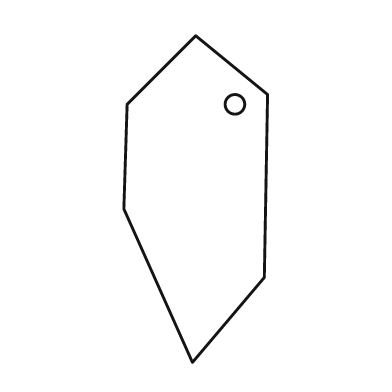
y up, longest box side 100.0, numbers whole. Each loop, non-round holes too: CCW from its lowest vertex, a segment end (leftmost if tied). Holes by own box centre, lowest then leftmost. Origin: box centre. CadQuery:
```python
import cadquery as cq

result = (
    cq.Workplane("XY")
    .moveTo(-1.0, -50.0)
    .lineTo(21.0, -24.0)
    .lineTo(22.0, 32.0)
    .lineTo(0.0, 50.0)
    .lineTo(-21.0, 29.0)
    .lineTo(-22.0, -3.0)
    .close()
    .moveTo(12.0, 29.0)
    .circle(3.0)
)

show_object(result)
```